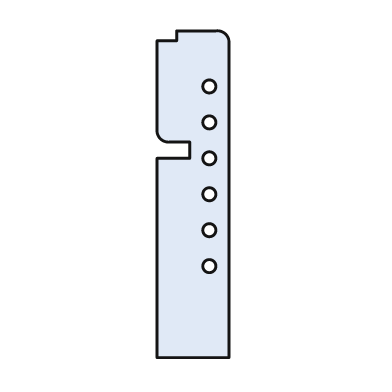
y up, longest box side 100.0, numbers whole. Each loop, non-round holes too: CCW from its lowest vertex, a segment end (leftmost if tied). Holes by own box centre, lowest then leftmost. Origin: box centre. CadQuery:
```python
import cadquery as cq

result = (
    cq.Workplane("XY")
    .moveTo(-11.0, -50.0)
    .lineTo(11.0, -50.0)
    .lineTo(11.0, 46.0)
    .threePointArc((10.0, 49.0), (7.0, 50.0))
    .lineTo(-5.0, 50.0)
    .lineTo(-5.0, 47.0)
    .lineTo(-11.0, 47.0)
    .lineTo(-11.0, 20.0)
    .threePointArc((-10.0, 17.0), (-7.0, 16.0))
    .lineTo(-1.0, 16.0)
    .lineTo(-1.0, 11.0)
    .lineTo(-11.0, 11.0)
    .close()
    .moveTo(5.0, -22.0)
    .circle(2.0)
    .moveTo(5.0, -11.0)
    .circle(2.0)
    .moveTo(5.0, 0.0)
    .circle(2.0)
    .moveTo(5.0, 11.0)
    .circle(2.0)
    .moveTo(5.0, 22.0)
    .circle(2.0)
    .moveTo(5.0, 33.0)
    .circle(2.0)
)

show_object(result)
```